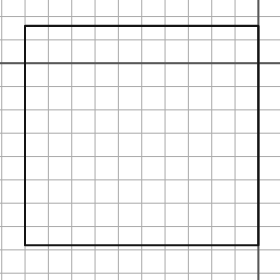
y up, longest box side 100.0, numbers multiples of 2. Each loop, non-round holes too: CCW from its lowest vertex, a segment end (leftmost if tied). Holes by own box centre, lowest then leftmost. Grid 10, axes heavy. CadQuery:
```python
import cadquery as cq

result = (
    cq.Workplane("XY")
    .moveTo(-100.0, -78.0)
    .lineTo(0.0, -78.0)
    .lineTo(0.0, 16.0)
    .lineTo(-100.0, 16.0)
    .close()
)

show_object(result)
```